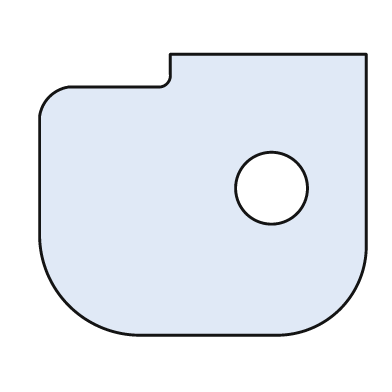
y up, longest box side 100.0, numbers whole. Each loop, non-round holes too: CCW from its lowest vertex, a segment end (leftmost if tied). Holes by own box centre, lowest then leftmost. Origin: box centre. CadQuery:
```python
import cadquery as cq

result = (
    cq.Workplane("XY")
    .moveTo(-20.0, -43.0)
    .lineTo(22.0, -43.0)
    .threePointArc((42.0, -35.0), (50.0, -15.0))
    .lineTo(50.0, 43.0)
    .lineTo(-10.0, 43.0)
    .lineTo(-10.0, 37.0)
    .threePointArc((-11.0, 34.0), (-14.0, 33.0))
    .lineTo(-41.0, 33.0)
    .threePointArc((-47.0, 30.0), (-50.0, 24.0))
    .lineTo(-50.0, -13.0)
    .threePointArc((-41.0, -34.0), (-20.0, -43.0))
    .close()
    .moveTo(21.0, 2.0)
    .circle(11.0)
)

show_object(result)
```